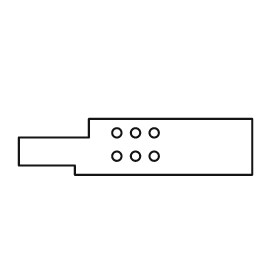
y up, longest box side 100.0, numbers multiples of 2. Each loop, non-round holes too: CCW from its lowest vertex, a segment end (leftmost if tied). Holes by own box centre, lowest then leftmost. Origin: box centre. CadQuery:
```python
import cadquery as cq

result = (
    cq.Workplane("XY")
    .moveTo(-26.0, -12.0)
    .lineTo(50.0, -12.0)
    .lineTo(50.0, 12.0)
    .lineTo(-20.0, 12.0)
    .lineTo(-20.0, 4.0)
    .lineTo(-50.0, 4.0)
    .lineTo(-50.0, -8.0)
    .lineTo(-26.0, -8.0)
    .close()
    .moveTo(-8.0, -4.0)
    .circle(2.0)
    .moveTo(0.0, -4.0)
    .circle(2.0)
    .moveTo(8.0, -4.0)
    .circle(2.0)
    .moveTo(-8.0, 6.0)
    .circle(2.0)
    .moveTo(0.0, 6.0)
    .circle(2.0)
    .moveTo(8.0, 6.0)
    .circle(2.0)
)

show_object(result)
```